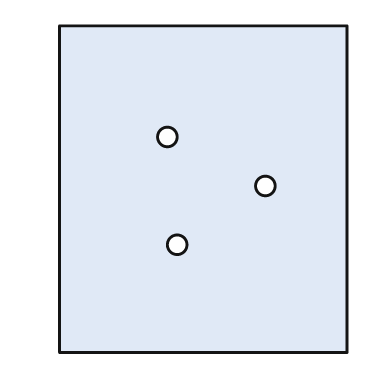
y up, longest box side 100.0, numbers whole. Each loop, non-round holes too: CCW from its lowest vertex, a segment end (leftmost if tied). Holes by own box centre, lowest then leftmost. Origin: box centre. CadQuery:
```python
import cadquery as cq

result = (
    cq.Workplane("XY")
    .moveTo(-44.0, -50.0)
    .lineTo(44.0, -50.0)
    .lineTo(44.0, 50.0)
    .lineTo(-44.0, 50.0)
    .close()
    .moveTo(-8.0, -17.0)
    .circle(3.0)
    .moveTo(19.0, 1.0)
    .circle(3.0)
    .moveTo(-11.0, 16.0)
    .circle(3.0)
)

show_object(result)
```